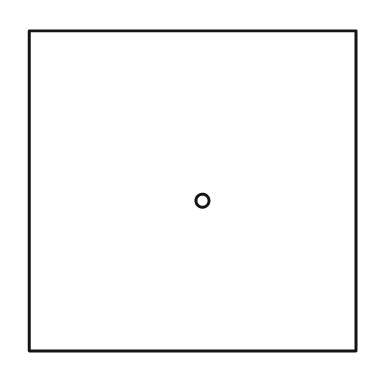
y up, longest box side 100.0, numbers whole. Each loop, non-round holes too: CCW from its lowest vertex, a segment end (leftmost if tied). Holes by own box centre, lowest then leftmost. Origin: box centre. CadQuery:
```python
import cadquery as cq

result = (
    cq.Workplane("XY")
    .moveTo(-50.0, -49.0)
    .lineTo(50.0, -49.0)
    .lineTo(50.0, 49.0)
    .lineTo(-50.0, 49.0)
    .close()
    .moveTo(3.0, -3.0)
    .circle(2.0)
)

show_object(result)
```